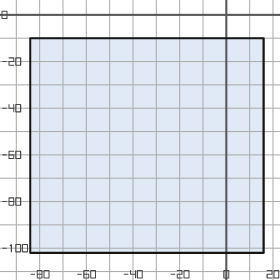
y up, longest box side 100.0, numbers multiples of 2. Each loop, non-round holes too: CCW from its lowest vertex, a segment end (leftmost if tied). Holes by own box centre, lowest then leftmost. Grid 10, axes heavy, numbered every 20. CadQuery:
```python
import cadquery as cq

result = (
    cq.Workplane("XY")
    .moveTo(-84.0, -102.0)
    .lineTo(16.0, -102.0)
    .lineTo(16.0, -10.0)
    .lineTo(-84.0, -10.0)
    .close()
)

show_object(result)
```